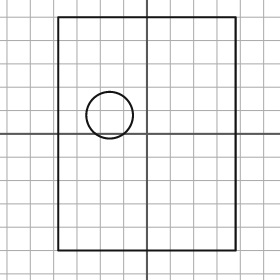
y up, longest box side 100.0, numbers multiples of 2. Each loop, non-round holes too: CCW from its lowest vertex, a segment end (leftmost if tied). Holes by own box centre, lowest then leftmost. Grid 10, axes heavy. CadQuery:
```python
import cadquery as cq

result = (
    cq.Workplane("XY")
    .moveTo(-38.0, -50.0)
    .lineTo(38.0, -50.0)
    .lineTo(38.0, 50.0)
    .lineTo(-38.0, 50.0)
    .close()
    .moveTo(-16.0, 8.0)
    .circle(10.0)
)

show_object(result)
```